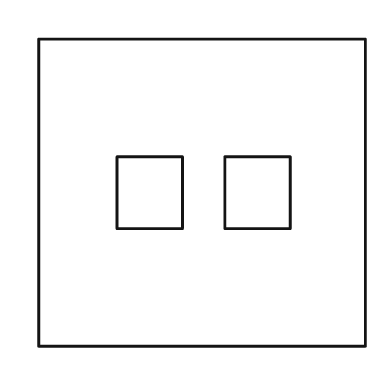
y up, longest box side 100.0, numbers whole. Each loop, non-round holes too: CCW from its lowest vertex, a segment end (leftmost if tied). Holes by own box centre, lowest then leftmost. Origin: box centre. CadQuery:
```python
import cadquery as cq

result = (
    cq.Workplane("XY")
    .moveTo(-50.0, -47.0)
    .lineTo(50.0, -47.0)
    .lineTo(50.0, 47.0)
    .lineTo(-50.0, 47.0)
    .close()
    .moveTo(-26.0, -11.0)
    .lineTo(-6.0, -11.0)
    .lineTo(-6.0, 11.0)
    .lineTo(-26.0, 11.0)
    .close()
    .moveTo(7.0, -11.0)
    .lineTo(27.0, -11.0)
    .lineTo(27.0, 11.0)
    .lineTo(7.0, 11.0)
    .close()
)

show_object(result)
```